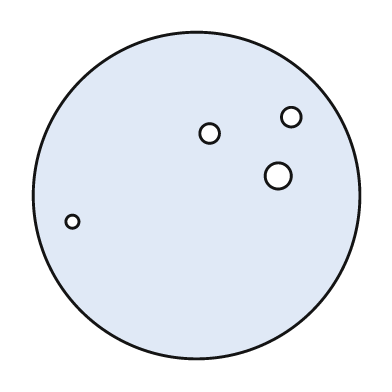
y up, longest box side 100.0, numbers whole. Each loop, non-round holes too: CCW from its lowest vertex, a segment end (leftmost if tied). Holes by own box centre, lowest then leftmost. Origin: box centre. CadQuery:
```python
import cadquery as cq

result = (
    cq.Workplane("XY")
    .moveTo(0.0, 0.0)
    .circle(50.0)
    .moveTo(-38.0, -8.0)
    .circle(2.0)
    .moveTo(25.0, 6.0)
    .circle(4.0)
    .moveTo(4.0, 19.0)
    .circle(3.0)
    .moveTo(29.0, 24.0)
    .circle(3.0)
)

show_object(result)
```